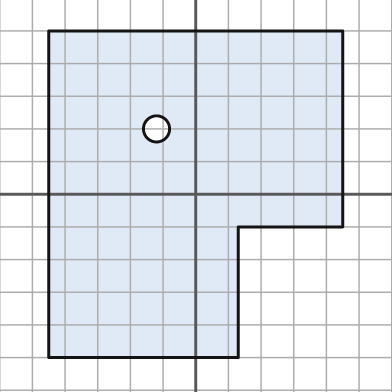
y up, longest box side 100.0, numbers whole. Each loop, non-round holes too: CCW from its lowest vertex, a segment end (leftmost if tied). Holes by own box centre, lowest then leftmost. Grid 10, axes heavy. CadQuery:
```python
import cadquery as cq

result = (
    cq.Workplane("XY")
    .moveTo(-45.0, -50.0)
    .lineTo(13.0, -50.0)
    .lineTo(13.0, -10.0)
    .lineTo(45.0, -10.0)
    .lineTo(45.0, 50.0)
    .lineTo(-45.0, 50.0)
    .close()
    .moveTo(-12.0, 20.0)
    .circle(4.0)
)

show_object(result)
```